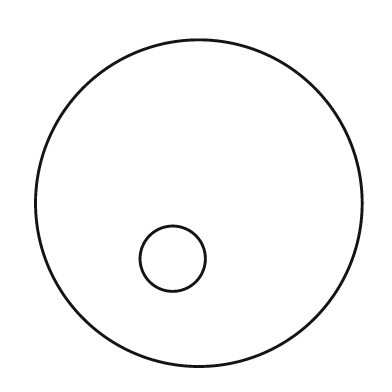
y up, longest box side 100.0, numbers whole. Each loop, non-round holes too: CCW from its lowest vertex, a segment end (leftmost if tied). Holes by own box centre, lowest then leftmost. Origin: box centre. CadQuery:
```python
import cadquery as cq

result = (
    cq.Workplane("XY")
    .moveTo(0.0, 0.0)
    .circle(50.0)
    .moveTo(-8.0, -17.0)
    .circle(10.0)
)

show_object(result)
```